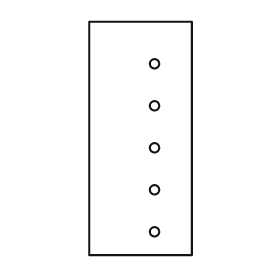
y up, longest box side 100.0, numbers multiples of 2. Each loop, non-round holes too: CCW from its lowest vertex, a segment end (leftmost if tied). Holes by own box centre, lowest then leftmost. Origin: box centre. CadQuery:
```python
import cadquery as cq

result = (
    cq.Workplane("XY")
    .moveTo(-22.0, -50.0)
    .lineTo(22.0, -50.0)
    .lineTo(22.0, 50.0)
    .lineTo(-22.0, 50.0)
    .close()
    .moveTo(6.0, -40.0)
    .circle(2.0)
    .moveTo(6.0, -22.0)
    .circle(2.0)
    .moveTo(6.0, -4.0)
    .circle(2.0)
    .moveTo(6.0, 14.0)
    .circle(2.0)
    .moveTo(6.0, 32.0)
    .circle(2.0)
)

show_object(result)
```